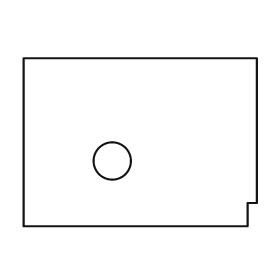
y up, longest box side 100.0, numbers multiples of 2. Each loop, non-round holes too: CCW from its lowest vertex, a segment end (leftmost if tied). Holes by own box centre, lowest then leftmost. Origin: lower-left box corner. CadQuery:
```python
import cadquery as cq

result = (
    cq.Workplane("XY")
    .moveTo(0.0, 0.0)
    .lineTo(96.0, 0.0)
    .lineTo(96.0, 10.0)
    .lineTo(100.0, 10.0)
    .lineTo(100.0, 72.0)
    .lineTo(0.0, 72.0)
    .close()
    .moveTo(38.0, 28.0)
    .circle(8.0)
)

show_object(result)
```